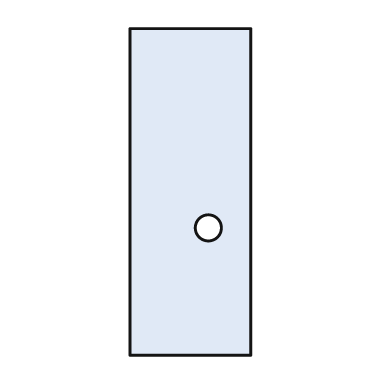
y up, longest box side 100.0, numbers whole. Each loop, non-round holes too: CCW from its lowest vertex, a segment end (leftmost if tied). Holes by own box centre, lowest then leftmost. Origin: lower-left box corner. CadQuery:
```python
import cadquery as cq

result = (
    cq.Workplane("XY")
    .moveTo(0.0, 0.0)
    .lineTo(37.0, 0.0)
    .lineTo(37.0, 100.0)
    .lineTo(0.0, 100.0)
    .close()
    .moveTo(24.0, 39.0)
    .circle(4.0)
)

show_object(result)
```